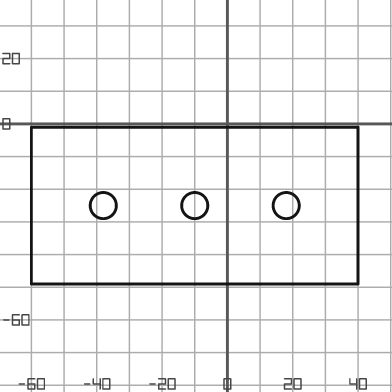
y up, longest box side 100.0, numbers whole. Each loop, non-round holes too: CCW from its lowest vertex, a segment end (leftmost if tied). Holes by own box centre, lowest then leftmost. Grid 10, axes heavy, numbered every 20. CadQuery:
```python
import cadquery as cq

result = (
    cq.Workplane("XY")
    .moveTo(-60.0, -49.0)
    .lineTo(40.0, -49.0)
    .lineTo(40.0, -1.0)
    .lineTo(-60.0, -1.0)
    .close()
    .moveTo(-38.0, -25.0)
    .circle(4.0)
    .moveTo(-10.0, -25.0)
    .circle(4.0)
    .moveTo(18.0, -25.0)
    .circle(4.0)
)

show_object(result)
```